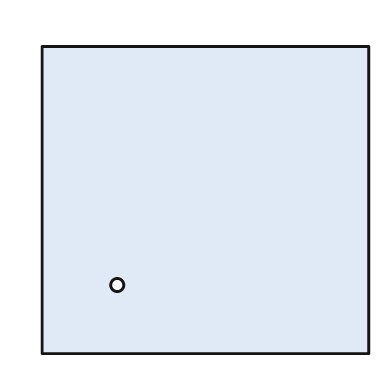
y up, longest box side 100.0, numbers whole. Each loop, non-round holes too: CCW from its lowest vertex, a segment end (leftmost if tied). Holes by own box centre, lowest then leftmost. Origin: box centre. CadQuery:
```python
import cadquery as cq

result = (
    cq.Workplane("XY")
    .moveTo(-50.0, -47.0)
    .lineTo(50.0, -47.0)
    .lineTo(50.0, 47.0)
    .lineTo(-50.0, 47.0)
    .close()
    .moveTo(-27.0, -26.0)
    .circle(2.0)
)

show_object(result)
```